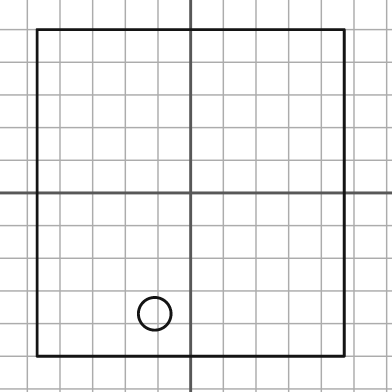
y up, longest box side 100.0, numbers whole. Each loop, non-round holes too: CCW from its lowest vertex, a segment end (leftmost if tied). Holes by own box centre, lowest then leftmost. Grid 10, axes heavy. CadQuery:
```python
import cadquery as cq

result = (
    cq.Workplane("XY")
    .moveTo(-47.0, -50.0)
    .lineTo(47.0, -50.0)
    .lineTo(47.0, 50.0)
    .lineTo(-47.0, 50.0)
    .close()
    .moveTo(-11.0, -37.0)
    .circle(5.0)
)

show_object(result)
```